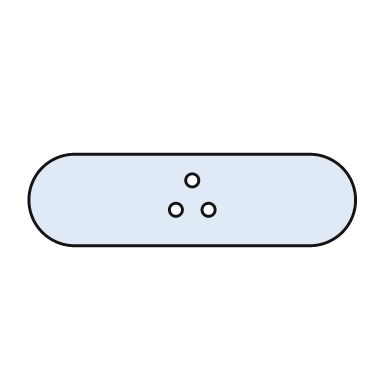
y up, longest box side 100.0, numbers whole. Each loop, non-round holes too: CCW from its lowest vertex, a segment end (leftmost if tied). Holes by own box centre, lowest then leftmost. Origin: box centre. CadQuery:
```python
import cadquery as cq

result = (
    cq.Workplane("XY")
    .moveTo(-36.0, -14.0)
    .lineTo(36.0, -14.0)
    .threePointArc((50.0, 0.0), (36.0, 14.0))
    .lineTo(-36.0, 14.0)
    .threePointArc((-50.0, 0.0), (-36.0, -14.0))
    .close()
    .moveTo(-5.0, -3.0)
    .circle(2.0)
    .moveTo(5.0, -3.0)
    .circle(2.0)
    .moveTo(0.0, 6.0)
    .circle(2.0)
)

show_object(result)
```